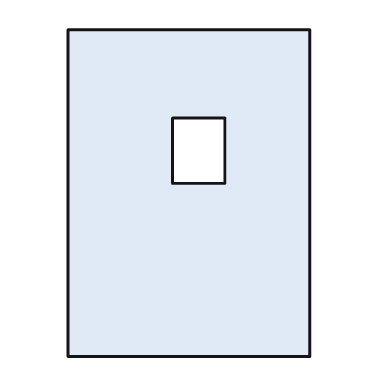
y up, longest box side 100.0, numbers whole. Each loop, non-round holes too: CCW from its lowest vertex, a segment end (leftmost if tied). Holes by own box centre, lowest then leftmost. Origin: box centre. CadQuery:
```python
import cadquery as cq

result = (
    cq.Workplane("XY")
    .moveTo(-37.0, -50.0)
    .lineTo(37.0, -50.0)
    .lineTo(37.0, 50.0)
    .lineTo(-37.0, 50.0)
    .close()
    .moveTo(-5.0, 3.0)
    .lineTo(11.0, 3.0)
    .lineTo(11.0, 23.0)
    .lineTo(-5.0, 23.0)
    .close()
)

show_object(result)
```